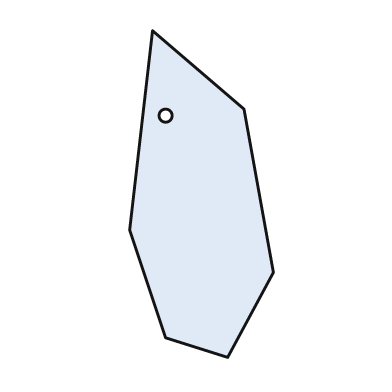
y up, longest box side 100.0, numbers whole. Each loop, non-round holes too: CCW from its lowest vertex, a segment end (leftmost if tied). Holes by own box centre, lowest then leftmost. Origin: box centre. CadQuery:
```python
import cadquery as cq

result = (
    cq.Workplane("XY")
    .moveTo(8.0, -50.0)
    .lineTo(22.0, -24.0)
    .lineTo(13.0, 26.0)
    .lineTo(-15.0, 50.0)
    .lineTo(-22.0, -11.0)
    .lineTo(-11.0, -44.0)
    .close()
    .moveTo(-11.0, 24.0)
    .circle(2.0)
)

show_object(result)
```